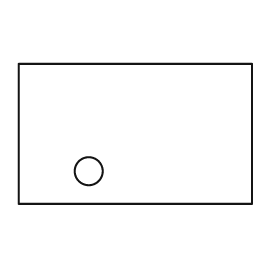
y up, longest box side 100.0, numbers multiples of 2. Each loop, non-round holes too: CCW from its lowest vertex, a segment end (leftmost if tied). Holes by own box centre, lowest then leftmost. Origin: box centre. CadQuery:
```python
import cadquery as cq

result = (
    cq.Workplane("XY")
    .moveTo(-50.0, -30.0)
    .lineTo(50.0, -30.0)
    .lineTo(50.0, 30.0)
    .lineTo(-50.0, 30.0)
    .close()
    .moveTo(-20.0, -16.0)
    .circle(6.0)
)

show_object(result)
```